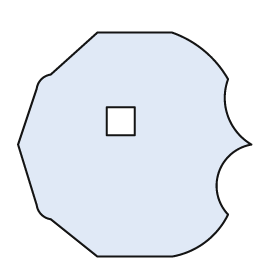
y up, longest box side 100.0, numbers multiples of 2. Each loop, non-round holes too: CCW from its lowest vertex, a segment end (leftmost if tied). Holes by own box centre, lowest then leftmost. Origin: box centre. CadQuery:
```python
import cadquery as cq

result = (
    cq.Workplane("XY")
    .moveTo(-16.0, -48.0)
    .lineTo(16.0, -48.0)
    .threePointArc((30.0, -42.0), (40.0, -30.0))
    .threePointArc((36.0, -12.0), (50.0, 0.0))
    .threePointArc((40.0, 12.0), (40.0, 28.0))
    .threePointArc((30.0, 40.0), (16.0, 48.0))
    .lineTo(-16.0, 48.0)
    .lineTo(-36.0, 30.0)
    .threePointArc((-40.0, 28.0), (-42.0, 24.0))
    .lineTo(-50.0, 0.0)
    .lineTo(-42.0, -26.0)
    .threePointArc((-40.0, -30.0), (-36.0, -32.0))
    .close()
    .moveTo(-12.0, 4.0)
    .lineTo(0.0, 4.0)
    .lineTo(0.0, 16.0)
    .lineTo(-12.0, 16.0)
    .close()
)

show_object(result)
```